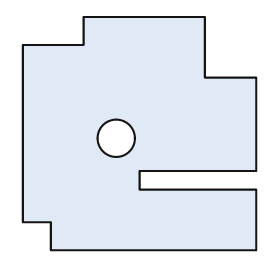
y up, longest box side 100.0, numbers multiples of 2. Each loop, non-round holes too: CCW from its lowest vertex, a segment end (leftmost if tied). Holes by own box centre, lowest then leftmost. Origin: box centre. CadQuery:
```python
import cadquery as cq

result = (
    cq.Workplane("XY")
    .moveTo(-38.0, -50.0)
    .lineTo(50.0, -50.0)
    .lineTo(50.0, -24.0)
    .lineTo(0.0, -24.0)
    .lineTo(0.0, -16.0)
    .lineTo(50.0, -16.0)
    .lineTo(50.0, 24.0)
    .lineTo(28.0, 24.0)
    .lineTo(28.0, 50.0)
    .lineTo(-24.0, 50.0)
    .lineTo(-24.0, 38.0)
    .lineTo(-50.0, 38.0)
    .lineTo(-50.0, -38.0)
    .lineTo(-38.0, -38.0)
    .close()
    .moveTo(-10.0, -2.0)
    .circle(8.0)
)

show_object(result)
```